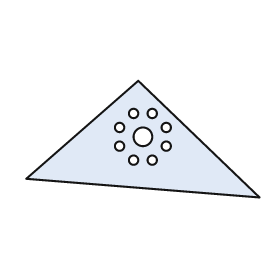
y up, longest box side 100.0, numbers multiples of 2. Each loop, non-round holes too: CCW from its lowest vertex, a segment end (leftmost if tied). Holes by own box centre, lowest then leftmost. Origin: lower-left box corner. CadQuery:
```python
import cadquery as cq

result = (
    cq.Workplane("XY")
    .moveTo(100.0, 0.0)
    .lineTo(48.0, 50.0)
    .lineTo(0.0, 8.0)
    .close()
    .moveTo(46.0, 16.0)
    .circle(2.0)
    .moveTo(54.0, 16.0)
    .circle(2.0)
    .moveTo(40.0, 22.0)
    .circle(2.0)
    .moveTo(60.0, 22.0)
    .circle(2.0)
    .moveTo(50.0, 26.0)
    .circle(4.0)
    .moveTo(40.0, 30.0)
    .circle(2.0)
    .moveTo(60.0, 30.0)
    .circle(2.0)
    .moveTo(46.0, 36.0)
    .circle(2.0)
    .moveTo(54.0, 36.0)
    .circle(2.0)
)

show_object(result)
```